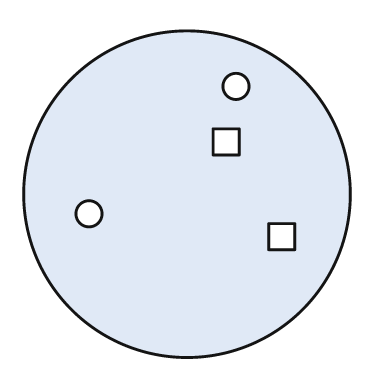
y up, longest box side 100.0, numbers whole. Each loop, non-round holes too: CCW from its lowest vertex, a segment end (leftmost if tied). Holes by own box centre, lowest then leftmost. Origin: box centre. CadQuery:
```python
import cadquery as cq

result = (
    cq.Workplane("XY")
    .moveTo(0.0, 0.0)
    .circle(50.0)
    .moveTo(25.0, -17.0)
    .lineTo(33.0, -17.0)
    .lineTo(33.0, -9.0)
    .lineTo(25.0, -9.0)
    .close()
    .moveTo(-30.0, -6.0)
    .circle(4.0)
    .moveTo(8.0, 12.0)
    .lineTo(16.0, 12.0)
    .lineTo(16.0, 20.0)
    .lineTo(8.0, 20.0)
    .close()
    .moveTo(15.0, 33.0)
    .circle(4.0)
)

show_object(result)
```